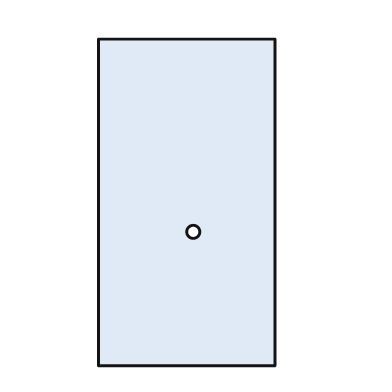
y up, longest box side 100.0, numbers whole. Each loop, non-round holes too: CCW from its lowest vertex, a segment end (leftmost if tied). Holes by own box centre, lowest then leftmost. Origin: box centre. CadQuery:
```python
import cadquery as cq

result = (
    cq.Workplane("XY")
    .moveTo(-27.0, -50.0)
    .lineTo(27.0, -50.0)
    .lineTo(27.0, 50.0)
    .lineTo(-27.0, 50.0)
    .close()
    .moveTo(2.0, -9.0)
    .circle(2.0)
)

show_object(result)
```